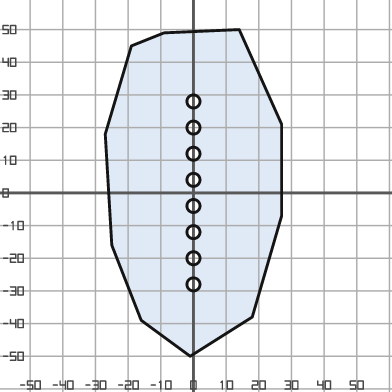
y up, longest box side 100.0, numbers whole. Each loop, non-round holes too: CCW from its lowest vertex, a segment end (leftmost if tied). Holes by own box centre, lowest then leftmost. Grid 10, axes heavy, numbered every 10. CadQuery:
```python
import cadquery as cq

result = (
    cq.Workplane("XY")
    .moveTo(-1.0, -50.0)
    .lineTo(18.0, -38.0)
    .lineTo(27.0, -7.0)
    .lineTo(27.0, 21.0)
    .lineTo(14.0, 50.0)
    .lineTo(-9.0, 49.0)
    .lineTo(-19.0, 45.0)
    .lineTo(-27.0, 18.0)
    .lineTo(-25.0, -16.0)
    .lineTo(-16.0, -39.0)
    .close()
    .moveTo(0.0, -28.0)
    .circle(2.0)
    .moveTo(0.0, -20.0)
    .circle(2.0)
    .moveTo(0.0, -12.0)
    .circle(2.0)
    .moveTo(0.0, -4.0)
    .circle(2.0)
    .moveTo(0.0, 4.0)
    .circle(2.0)
    .moveTo(0.0, 12.0)
    .circle(2.0)
    .moveTo(0.0, 20.0)
    .circle(2.0)
    .moveTo(0.0, 28.0)
    .circle(2.0)
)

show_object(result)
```